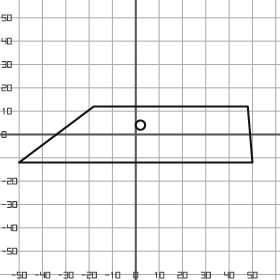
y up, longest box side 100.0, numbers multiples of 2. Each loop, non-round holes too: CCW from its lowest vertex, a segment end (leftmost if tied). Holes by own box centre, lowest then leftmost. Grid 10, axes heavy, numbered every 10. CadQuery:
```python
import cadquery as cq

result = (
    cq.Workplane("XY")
    .moveTo(-50.0, -12.0)
    .lineTo(50.0, -12.0)
    .lineTo(48.0, 12.0)
    .lineTo(-18.0, 12.0)
    .close()
    .moveTo(2.0, 4.0)
    .circle(2.0)
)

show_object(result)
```